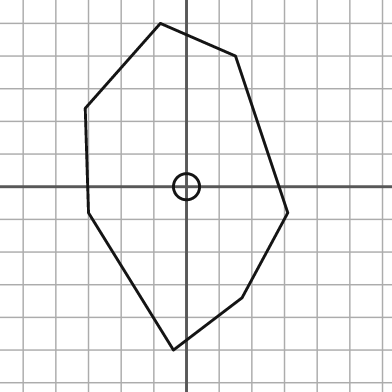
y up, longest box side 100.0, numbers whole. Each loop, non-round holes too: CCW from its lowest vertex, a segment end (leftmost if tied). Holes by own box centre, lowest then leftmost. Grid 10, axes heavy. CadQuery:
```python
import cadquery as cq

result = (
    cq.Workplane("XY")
    .moveTo(-4.0, -50.0)
    .lineTo(17.0, -34.0)
    .lineTo(31.0, -8.0)
    .lineTo(15.0, 40.0)
    .lineTo(-8.0, 50.0)
    .lineTo(-31.0, 24.0)
    .lineTo(-30.0, -8.0)
    .close()
    .moveTo(0.0, 0.0)
    .circle(4.0)
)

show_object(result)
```